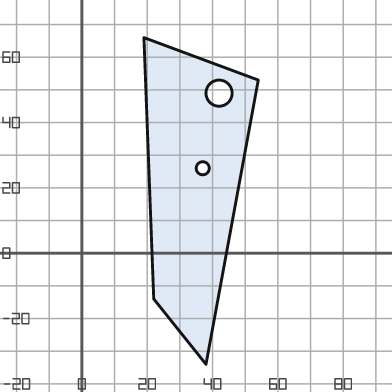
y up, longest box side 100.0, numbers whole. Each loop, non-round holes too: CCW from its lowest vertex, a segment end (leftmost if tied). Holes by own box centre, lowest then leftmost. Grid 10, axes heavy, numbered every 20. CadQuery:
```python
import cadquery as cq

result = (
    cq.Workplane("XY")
    .moveTo(38.0, -34.0)
    .lineTo(54.0, 53.0)
    .lineTo(19.0, 66.0)
    .lineTo(22.0, -14.0)
    .close()
    .moveTo(37.0, 26.0)
    .circle(2.0)
    .moveTo(42.0, 49.0)
    .circle(4.0)
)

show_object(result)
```